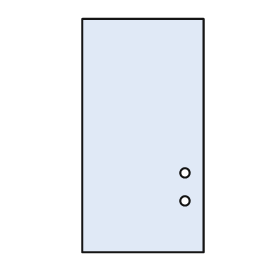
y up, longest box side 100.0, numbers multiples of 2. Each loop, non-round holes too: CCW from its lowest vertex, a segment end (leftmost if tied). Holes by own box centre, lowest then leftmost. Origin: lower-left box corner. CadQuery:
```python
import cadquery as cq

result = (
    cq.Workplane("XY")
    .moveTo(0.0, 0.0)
    .lineTo(52.0, 0.0)
    .lineTo(52.0, 100.0)
    .lineTo(0.0, 100.0)
    .close()
    .moveTo(44.0, 22.0)
    .circle(2.0)
    .moveTo(44.0, 34.0)
    .circle(2.0)
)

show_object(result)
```